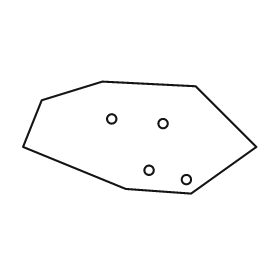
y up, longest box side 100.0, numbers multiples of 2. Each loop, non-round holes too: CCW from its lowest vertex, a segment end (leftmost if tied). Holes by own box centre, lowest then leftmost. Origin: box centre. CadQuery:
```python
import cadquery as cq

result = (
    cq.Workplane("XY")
    .moveTo(22.0, -24.0)
    .lineTo(50.0, -4.0)
    .lineTo(24.0, 22.0)
    .lineTo(-16.0, 24.0)
    .lineTo(-42.0, 16.0)
    .lineTo(-50.0, -4.0)
    .lineTo(-6.0, -22.0)
    .close()
    .moveTo(20.0, -18.0)
    .circle(2.0)
    .moveTo(4.0, -14.0)
    .circle(2.0)
    .moveTo(10.0, 6.0)
    .circle(2.0)
    .moveTo(-12.0, 8.0)
    .circle(2.0)
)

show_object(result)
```